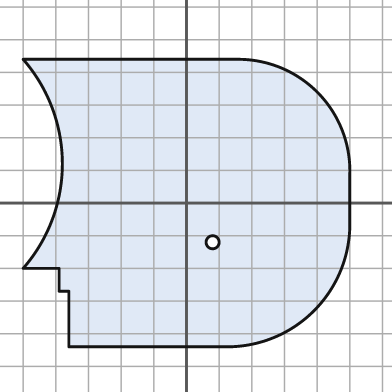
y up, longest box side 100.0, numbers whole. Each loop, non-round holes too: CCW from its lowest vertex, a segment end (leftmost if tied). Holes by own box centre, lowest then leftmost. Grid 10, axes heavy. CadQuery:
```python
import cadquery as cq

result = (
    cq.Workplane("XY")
    .moveTo(-36.0, -44.0)
    .lineTo(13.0, -44.0)
    .threePointArc((39.0, -33.0), (50.0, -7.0))
    .lineTo(50.0, 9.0)
    .threePointArc((40.0, 34.0), (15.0, 44.0))
    .lineTo(-50.0, 44.0)
    .threePointArc((-38.0, 12.0), (-50.0, -20.0))
    .lineTo(-39.0, -20.0)
    .lineTo(-39.0, -27.0)
    .lineTo(-36.0, -27.0)
    .close()
    .moveTo(8.0, -12.0)
    .circle(2.0)
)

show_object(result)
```